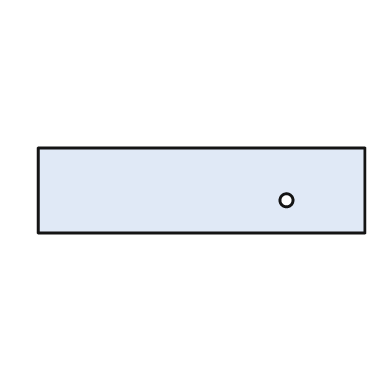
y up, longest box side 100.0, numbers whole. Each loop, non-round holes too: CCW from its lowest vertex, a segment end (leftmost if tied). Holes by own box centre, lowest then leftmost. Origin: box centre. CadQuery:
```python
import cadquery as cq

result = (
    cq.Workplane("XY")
    .moveTo(-50.0, -13.0)
    .lineTo(50.0, -13.0)
    .lineTo(50.0, 13.0)
    .lineTo(-50.0, 13.0)
    .close()
    .moveTo(26.0, -3.0)
    .circle(2.0)
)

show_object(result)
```